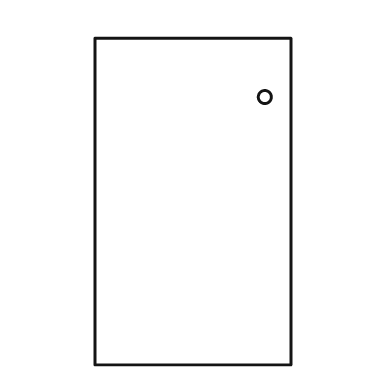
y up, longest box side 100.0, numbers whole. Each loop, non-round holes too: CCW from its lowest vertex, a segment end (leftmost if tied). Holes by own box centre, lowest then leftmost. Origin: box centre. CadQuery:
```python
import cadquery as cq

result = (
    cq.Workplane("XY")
    .moveTo(-30.0, -50.0)
    .lineTo(30.0, -50.0)
    .lineTo(30.0, 50.0)
    .lineTo(-30.0, 50.0)
    .close()
    .moveTo(22.0, 32.0)
    .circle(2.0)
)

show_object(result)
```